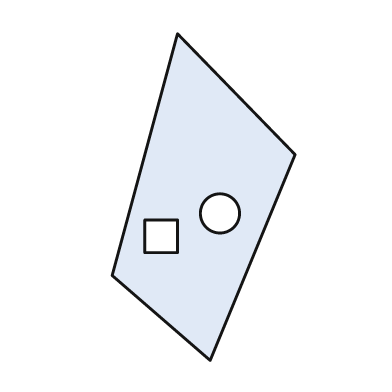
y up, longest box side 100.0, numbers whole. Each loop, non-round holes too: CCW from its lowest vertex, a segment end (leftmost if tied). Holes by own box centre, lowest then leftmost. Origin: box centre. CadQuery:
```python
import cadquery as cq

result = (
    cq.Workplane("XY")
    .moveTo(2.0, -50.0)
    .lineTo(28.0, 13.0)
    .lineTo(-8.0, 50.0)
    .lineTo(-28.0, -24.0)
    .close()
    .moveTo(-18.0, -17.0)
    .lineTo(-8.0, -17.0)
    .lineTo(-8.0, -7.0)
    .lineTo(-18.0, -7.0)
    .close()
    .moveTo(5.0, -5.0)
    .circle(6.0)
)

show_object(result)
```